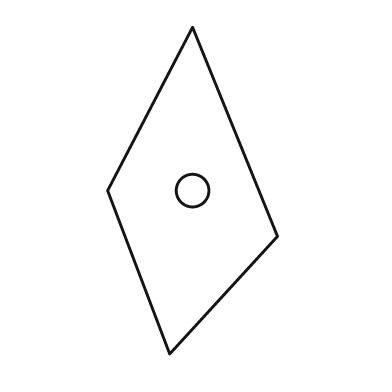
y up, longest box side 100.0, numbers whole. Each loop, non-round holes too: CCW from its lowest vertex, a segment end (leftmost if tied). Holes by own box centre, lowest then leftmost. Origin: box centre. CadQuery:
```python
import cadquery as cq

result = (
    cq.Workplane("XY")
    .moveTo(-7.0, -50.0)
    .lineTo(26.0, -14.0)
    .lineTo(0.0, 50.0)
    .lineTo(-26.0, 0.0)
    .close()
    .moveTo(0.0, 0.0)
    .circle(5.0)
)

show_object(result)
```